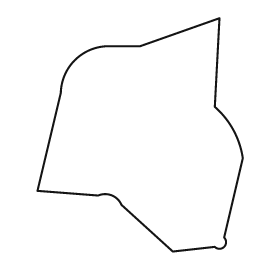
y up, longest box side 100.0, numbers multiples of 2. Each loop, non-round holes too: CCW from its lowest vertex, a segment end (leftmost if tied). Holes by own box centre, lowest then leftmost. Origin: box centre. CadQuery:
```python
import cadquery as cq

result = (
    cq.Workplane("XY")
    .moveTo(14.0, -50.0)
    .lineTo(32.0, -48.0)
    .threePointArc((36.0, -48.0), (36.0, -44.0))
    .lineTo(44.0, -10.0)
    .threePointArc((40.0, 2.0), (32.0, 12.0))
    .lineTo(34.0, 50.0)
    .lineTo(0.0, 38.0)
    .lineTo(-14.0, 38.0)
    .threePointArc((-28.0, 32.0), (-34.0, 18.0))
    .lineTo(-44.0, -24.0)
    .lineTo(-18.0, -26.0)
    .threePointArc((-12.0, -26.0), (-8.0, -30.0))
    .close()
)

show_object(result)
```